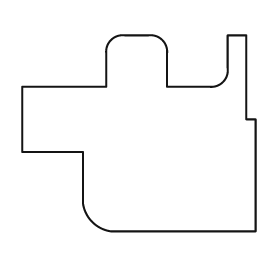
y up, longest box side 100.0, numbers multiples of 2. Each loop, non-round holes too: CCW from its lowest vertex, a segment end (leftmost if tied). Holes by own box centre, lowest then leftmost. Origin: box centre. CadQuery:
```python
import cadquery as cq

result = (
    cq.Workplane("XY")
    .moveTo(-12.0, -42.0)
    .lineTo(50.0, -42.0)
    .lineTo(50.0, 6.0)
    .lineTo(46.0, 6.0)
    .lineTo(46.0, 42.0)
    .lineTo(38.0, 42.0)
    .lineTo(38.0, 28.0)
    .threePointArc((36.0, 22.0), (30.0, 20.0))
    .lineTo(12.0, 20.0)
    .lineTo(12.0, 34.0)
    .threePointArc((10.0, 40.0), (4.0, 42.0))
    .lineTo(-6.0, 42.0)
    .threePointArc((-12.0, 40.0), (-14.0, 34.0))
    .lineTo(-14.0, 20.0)
    .lineTo(-50.0, 20.0)
    .lineTo(-50.0, -8.0)
    .lineTo(-24.0, -8.0)
    .lineTo(-24.0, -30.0)
    .threePointArc((-20.0, -38.0), (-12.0, -42.0))
    .close()
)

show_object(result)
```